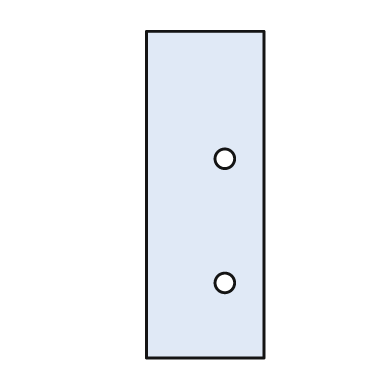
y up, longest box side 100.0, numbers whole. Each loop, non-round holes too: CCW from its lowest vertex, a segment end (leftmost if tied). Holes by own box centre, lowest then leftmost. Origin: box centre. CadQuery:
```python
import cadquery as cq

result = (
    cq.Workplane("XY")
    .moveTo(-18.0, -50.0)
    .lineTo(18.0, -50.0)
    .lineTo(18.0, 50.0)
    .lineTo(-18.0, 50.0)
    .close()
    .moveTo(6.0, -27.0)
    .circle(3.0)
    .moveTo(6.0, 11.0)
    .circle(3.0)
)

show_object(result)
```